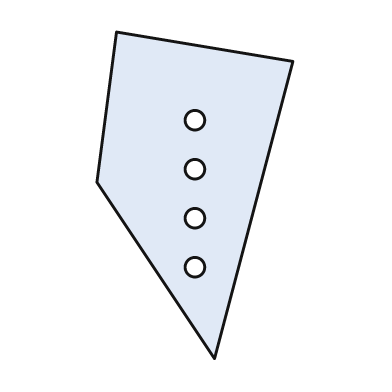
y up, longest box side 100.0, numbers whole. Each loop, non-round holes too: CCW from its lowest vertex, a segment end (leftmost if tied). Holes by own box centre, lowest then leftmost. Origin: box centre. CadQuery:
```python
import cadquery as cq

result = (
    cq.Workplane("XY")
    .moveTo(6.0, -50.0)
    .lineTo(30.0, 41.0)
    .lineTo(-24.0, 50.0)
    .lineTo(-30.0, 4.0)
    .close()
    .moveTo(0.0, -22.0)
    .circle(3.0)
    .moveTo(0.0, -7.0)
    .circle(3.0)
    .moveTo(0.0, 8.0)
    .circle(3.0)
    .moveTo(0.0, 23.0)
    .circle(3.0)
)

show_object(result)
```